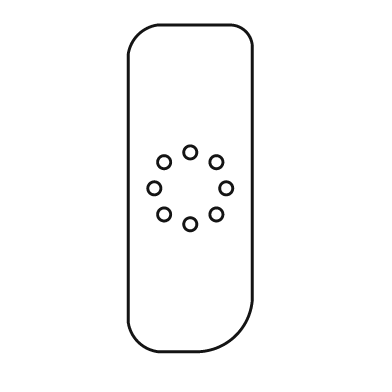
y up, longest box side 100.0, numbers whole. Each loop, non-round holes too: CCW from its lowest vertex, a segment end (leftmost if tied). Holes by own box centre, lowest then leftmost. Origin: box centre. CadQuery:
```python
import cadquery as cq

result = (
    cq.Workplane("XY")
    .moveTo(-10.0, -50.0)
    .lineTo(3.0, -50.0)
    .threePointArc((14.0, -45.0), (19.0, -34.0))
    .lineTo(19.0, 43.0)
    .threePointArc((17.0, 48.0), (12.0, 50.0))
    .lineTo(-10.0, 50.0)
    .threePointArc((-16.0, 47.0), (-19.0, 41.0))
    .lineTo(-19.0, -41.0)
    .threePointArc((-16.0, -47.0), (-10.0, -50.0))
    .close()
    .moveTo(0.0, -11.0)
    .circle(2.0)
    .moveTo(-8.0, -8.0)
    .circle(2.0)
    .moveTo(8.0, -8.0)
    .circle(2.0)
    .moveTo(-11.0, 0.0)
    .circle(2.0)
    .moveTo(11.0, 0.0)
    .circle(2.0)
    .moveTo(-8.0, 8.0)
    .circle(2.0)
    .moveTo(8.0, 8.0)
    .circle(2.0)
    .moveTo(0.0, 11.0)
    .circle(2.0)
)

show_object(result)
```